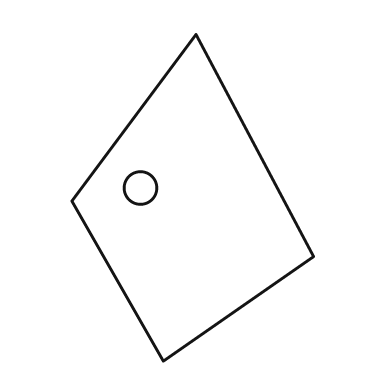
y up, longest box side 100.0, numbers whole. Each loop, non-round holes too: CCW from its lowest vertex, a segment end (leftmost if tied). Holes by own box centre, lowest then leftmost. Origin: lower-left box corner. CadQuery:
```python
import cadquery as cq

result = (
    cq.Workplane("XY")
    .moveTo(28.0, 0.0)
    .lineTo(74.0, 32.0)
    .lineTo(38.0, 100.0)
    .lineTo(0.0, 49.0)
    .close()
    .moveTo(21.0, 53.0)
    .circle(5.0)
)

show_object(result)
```